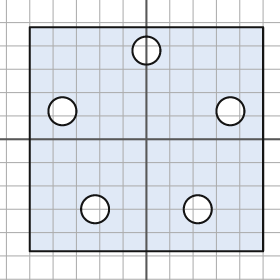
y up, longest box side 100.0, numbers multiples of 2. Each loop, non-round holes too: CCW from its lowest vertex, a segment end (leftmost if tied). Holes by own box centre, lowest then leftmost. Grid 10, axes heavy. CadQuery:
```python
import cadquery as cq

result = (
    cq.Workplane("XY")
    .moveTo(-50.0, -48.0)
    .lineTo(50.0, -48.0)
    .lineTo(50.0, 48.0)
    .lineTo(-50.0, 48.0)
    .close()
    .moveTo(-22.0, -30.0)
    .circle(6.0)
    .moveTo(22.0, -30.0)
    .circle(6.0)
    .moveTo(-36.0, 12.0)
    .circle(6.0)
    .moveTo(36.0, 12.0)
    .circle(6.0)
    .moveTo(0.0, 38.0)
    .circle(6.0)
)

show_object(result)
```